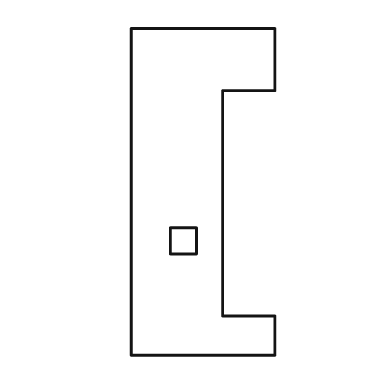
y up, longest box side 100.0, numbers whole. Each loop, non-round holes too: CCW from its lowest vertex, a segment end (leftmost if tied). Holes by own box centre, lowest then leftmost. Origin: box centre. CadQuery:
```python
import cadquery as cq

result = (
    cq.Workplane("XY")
    .moveTo(-22.0, -50.0)
    .lineTo(22.0, -50.0)
    .lineTo(22.0, -38.0)
    .lineTo(6.0, -38.0)
    .lineTo(6.0, 31.0)
    .lineTo(22.0, 31.0)
    .lineTo(22.0, 50.0)
    .lineTo(-22.0, 50.0)
    .close()
    .moveTo(-10.0, -19.0)
    .lineTo(-2.0, -19.0)
    .lineTo(-2.0, -11.0)
    .lineTo(-10.0, -11.0)
    .close()
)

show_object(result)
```